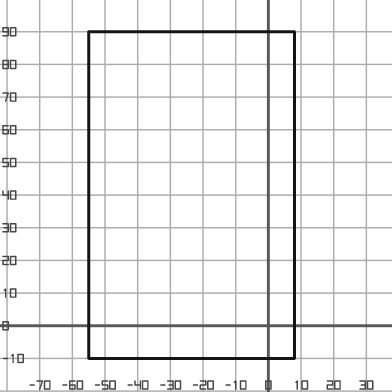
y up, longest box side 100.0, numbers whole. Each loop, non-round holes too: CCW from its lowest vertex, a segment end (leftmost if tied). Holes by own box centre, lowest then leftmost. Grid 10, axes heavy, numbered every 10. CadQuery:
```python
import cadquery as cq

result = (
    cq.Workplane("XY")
    .moveTo(-55.0, -10.0)
    .lineTo(8.0, -10.0)
    .lineTo(8.0, 90.0)
    .lineTo(-55.0, 90.0)
    .close()
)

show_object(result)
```